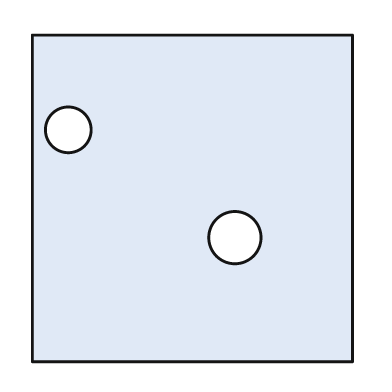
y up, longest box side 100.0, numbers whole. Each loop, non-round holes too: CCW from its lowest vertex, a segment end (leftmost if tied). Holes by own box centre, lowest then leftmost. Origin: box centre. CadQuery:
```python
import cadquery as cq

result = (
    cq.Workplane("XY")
    .moveTo(-49.0, -50.0)
    .lineTo(49.0, -50.0)
    .lineTo(49.0, 50.0)
    .lineTo(-49.0, 50.0)
    .close()
    .moveTo(13.0, -12.0)
    .circle(8.0)
    .moveTo(-38.0, 21.0)
    .circle(7.0)
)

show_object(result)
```